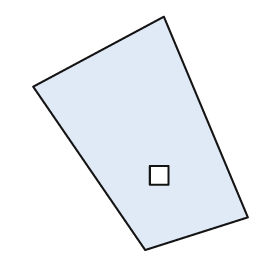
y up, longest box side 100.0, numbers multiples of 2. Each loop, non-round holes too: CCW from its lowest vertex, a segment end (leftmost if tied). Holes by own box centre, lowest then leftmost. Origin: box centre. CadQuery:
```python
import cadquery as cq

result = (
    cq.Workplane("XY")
    .moveTo(2.0, -50.0)
    .lineTo(46.0, -36.0)
    .lineTo(10.0, 50.0)
    .lineTo(-46.0, 20.0)
    .close()
    .moveTo(4.0, -22.0)
    .lineTo(12.0, -22.0)
    .lineTo(12.0, -14.0)
    .lineTo(4.0, -14.0)
    .close()
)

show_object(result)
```